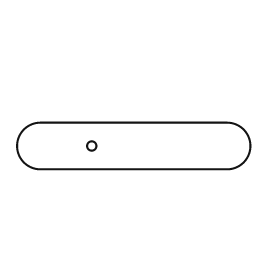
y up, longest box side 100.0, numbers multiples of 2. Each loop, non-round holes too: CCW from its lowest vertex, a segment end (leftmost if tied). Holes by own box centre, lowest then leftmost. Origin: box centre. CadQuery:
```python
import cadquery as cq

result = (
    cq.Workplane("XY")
    .moveTo(-40.0, -10.0)
    .lineTo(40.0, -10.0)
    .threePointArc((50.0, 0.0), (40.0, 10.0))
    .lineTo(-40.0, 10.0)
    .threePointArc((-50.0, 0.0), (-40.0, -10.0))
    .close()
    .moveTo(-18.0, 0.0)
    .circle(2.0)
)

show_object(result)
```